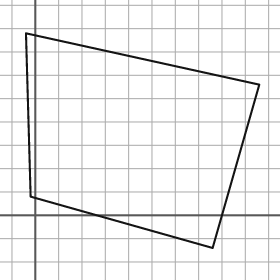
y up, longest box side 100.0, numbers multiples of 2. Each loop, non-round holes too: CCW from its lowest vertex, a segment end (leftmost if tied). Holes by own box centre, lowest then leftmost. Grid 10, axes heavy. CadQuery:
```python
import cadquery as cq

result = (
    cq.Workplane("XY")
    .moveTo(76.0, -14.0)
    .lineTo(96.0, 56.0)
    .lineTo(-4.0, 78.0)
    .lineTo(-2.0, 8.0)
    .close()
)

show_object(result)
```